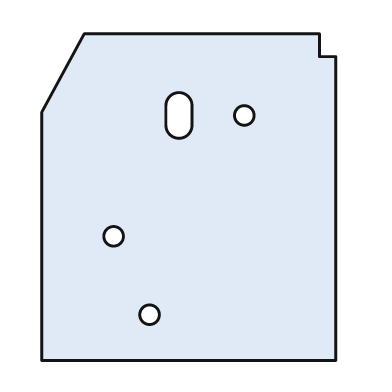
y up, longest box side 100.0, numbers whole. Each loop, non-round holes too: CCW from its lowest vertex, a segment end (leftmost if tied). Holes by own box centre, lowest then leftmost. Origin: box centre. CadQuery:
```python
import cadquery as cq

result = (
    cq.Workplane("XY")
    .moveTo(-45.0, -50.0)
    .lineTo(45.0, -50.0)
    .lineTo(45.0, 43.0)
    .lineTo(40.0, 43.0)
    .lineTo(40.0, 50.0)
    .lineTo(-32.0, 50.0)
    .lineTo(-45.0, 26.0)
    .close()
    .moveTo(-12.0, -36.0)
    .circle(3.0)
    .moveTo(-23.0, -12.0)
    .circle(3.0)
    .moveTo(-7.0, 22.0)
    .threePointArc((-3.0, 18.0), (1.0, 22.0))
    .lineTo(1.0, 28.0)
    .threePointArc((-3.0, 32.0), (-7.0, 28.0))
    .close()
    .moveTo(17.0, 25.0)
    .circle(3.0)
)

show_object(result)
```